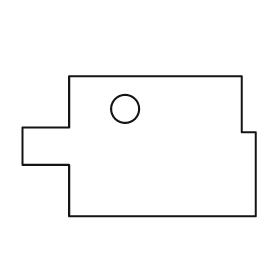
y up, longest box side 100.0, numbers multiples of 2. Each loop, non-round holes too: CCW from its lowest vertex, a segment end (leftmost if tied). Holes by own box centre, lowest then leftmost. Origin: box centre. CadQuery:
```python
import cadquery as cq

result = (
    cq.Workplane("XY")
    .moveTo(-30.0, -30.0)
    .lineTo(50.0, -30.0)
    .lineTo(50.0, 6.0)
    .lineTo(44.0, 6.0)
    .lineTo(44.0, 30.0)
    .lineTo(-30.0, 30.0)
    .lineTo(-30.0, 8.0)
    .lineTo(-50.0, 8.0)
    .lineTo(-50.0, -8.0)
    .lineTo(-30.0, -8.0)
    .close()
    .moveTo(-6.0, 16.0)
    .circle(6.0)
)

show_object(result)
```